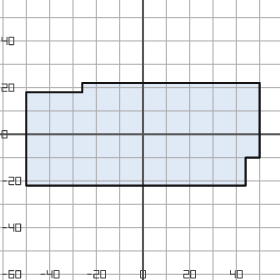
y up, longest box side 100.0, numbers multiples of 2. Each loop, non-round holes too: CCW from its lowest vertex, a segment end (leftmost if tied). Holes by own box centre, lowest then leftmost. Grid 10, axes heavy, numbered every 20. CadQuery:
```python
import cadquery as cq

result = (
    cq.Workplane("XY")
    .moveTo(-50.0, -22.0)
    .lineTo(44.0, -22.0)
    .lineTo(44.0, -10.0)
    .lineTo(50.0, -10.0)
    .lineTo(50.0, 22.0)
    .lineTo(-26.0, 22.0)
    .lineTo(-26.0, 18.0)
    .lineTo(-50.0, 18.0)
    .close()
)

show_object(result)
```